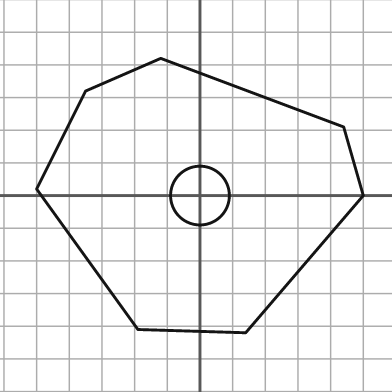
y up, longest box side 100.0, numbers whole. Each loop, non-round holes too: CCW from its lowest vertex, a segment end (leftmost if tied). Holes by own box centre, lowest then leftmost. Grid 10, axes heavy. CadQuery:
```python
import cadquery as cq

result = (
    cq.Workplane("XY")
    .moveTo(14.0, -42.0)
    .lineTo(50.0, 0.0)
    .lineTo(44.0, 21.0)
    .lineTo(-12.0, 42.0)
    .lineTo(-35.0, 32.0)
    .lineTo(-50.0, 2.0)
    .lineTo(-19.0, -41.0)
    .close()
    .moveTo(0.0, 0.0)
    .circle(9.0)
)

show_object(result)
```